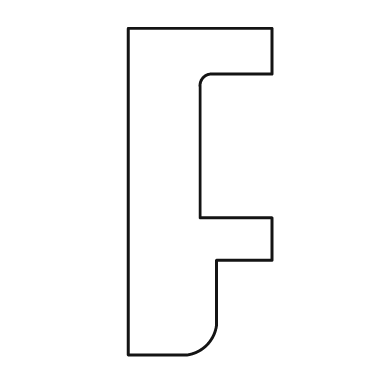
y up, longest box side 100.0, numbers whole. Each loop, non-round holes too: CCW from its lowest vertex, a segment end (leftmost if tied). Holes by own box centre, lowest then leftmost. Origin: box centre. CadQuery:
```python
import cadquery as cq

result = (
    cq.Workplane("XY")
    .moveTo(-22.0, -50.0)
    .lineTo(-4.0, -50.0)
    .threePointArc((2.0, -47.0), (5.0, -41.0))
    .lineTo(5.0, -21.0)
    .lineTo(22.0, -21.0)
    .lineTo(22.0, -8.0)
    .lineTo(0.0, -8.0)
    .lineTo(0.0, 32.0)
    .threePointArc((1.0, 35.0), (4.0, 36.0))
    .lineTo(22.0, 36.0)
    .lineTo(22.0, 50.0)
    .lineTo(-22.0, 50.0)
    .close()
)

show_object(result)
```